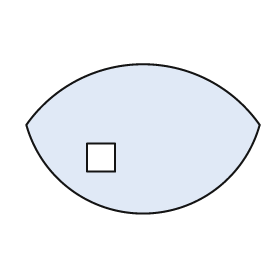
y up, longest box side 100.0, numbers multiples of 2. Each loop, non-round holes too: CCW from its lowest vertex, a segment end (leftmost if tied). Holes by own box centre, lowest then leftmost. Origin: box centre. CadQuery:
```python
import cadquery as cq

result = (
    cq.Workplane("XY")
    .moveTo(-50.0, 6.0)
    .threePointArc((0.0, -32.0), (50.0, 6.0))
    .threePointArc((0.0, 32.0), (-50.0, 6.0))
    .close()
    .moveTo(-24.0, -14.0)
    .lineTo(-12.0, -14.0)
    .lineTo(-12.0, -2.0)
    .lineTo(-24.0, -2.0)
    .close()
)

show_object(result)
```